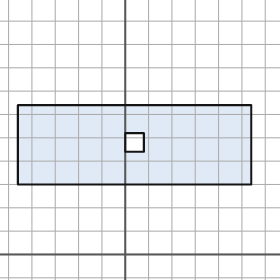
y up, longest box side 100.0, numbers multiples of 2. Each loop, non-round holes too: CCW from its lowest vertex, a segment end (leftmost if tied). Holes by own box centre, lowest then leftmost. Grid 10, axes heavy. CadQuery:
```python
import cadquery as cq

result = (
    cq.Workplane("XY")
    .moveTo(-46.0, 30.0)
    .lineTo(54.0, 30.0)
    .lineTo(54.0, 64.0)
    .lineTo(-46.0, 64.0)
    .close()
    .moveTo(0.0, 44.0)
    .lineTo(8.0, 44.0)
    .lineTo(8.0, 52.0)
    .lineTo(0.0, 52.0)
    .close()
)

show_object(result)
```